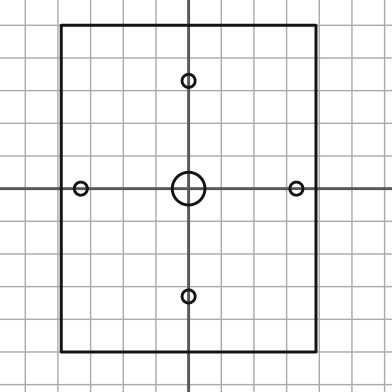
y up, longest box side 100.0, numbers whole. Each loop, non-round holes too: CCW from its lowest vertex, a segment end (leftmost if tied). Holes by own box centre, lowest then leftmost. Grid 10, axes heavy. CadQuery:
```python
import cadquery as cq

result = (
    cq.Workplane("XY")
    .moveTo(-39.0, -50.0)
    .lineTo(39.0, -50.0)
    .lineTo(39.0, 50.0)
    .lineTo(-39.0, 50.0)
    .close()
    .moveTo(0.0, -33.0)
    .circle(2.0)
    .moveTo(-33.0, 0.0)
    .circle(2.0)
    .moveTo(0.0, 0.0)
    .circle(5.0)
    .moveTo(33.0, 0.0)
    .circle(2.0)
    .moveTo(0.0, 33.0)
    .circle(2.0)
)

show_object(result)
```